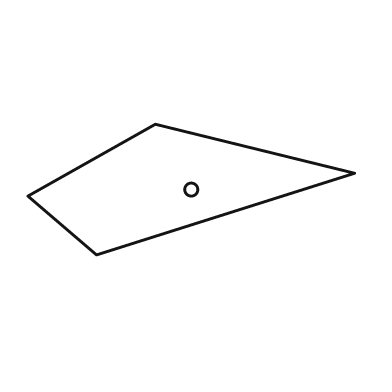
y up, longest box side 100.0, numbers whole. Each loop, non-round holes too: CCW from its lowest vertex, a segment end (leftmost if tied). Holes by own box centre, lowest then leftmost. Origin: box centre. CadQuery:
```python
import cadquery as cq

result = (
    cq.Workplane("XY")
    .moveTo(-29.0, -20.0)
    .lineTo(50.0, 5.0)
    .lineTo(-11.0, 20.0)
    .lineTo(-50.0, -2.0)
    .close()
    .moveTo(0.0, 0.0)
    .circle(2.0)
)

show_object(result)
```